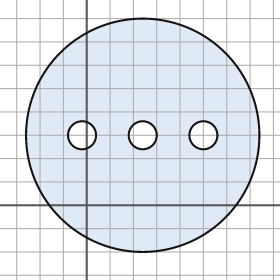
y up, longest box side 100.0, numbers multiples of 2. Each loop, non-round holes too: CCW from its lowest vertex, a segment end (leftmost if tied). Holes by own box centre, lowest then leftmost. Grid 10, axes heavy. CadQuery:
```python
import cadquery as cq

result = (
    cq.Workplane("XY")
    .moveTo(24.0, 30.0)
    .circle(50.0)
    .moveTo(-2.0, 30.0)
    .circle(6.0)
    .moveTo(24.0, 30.0)
    .circle(6.0)
    .moveTo(50.0, 30.0)
    .circle(6.0)
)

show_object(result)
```